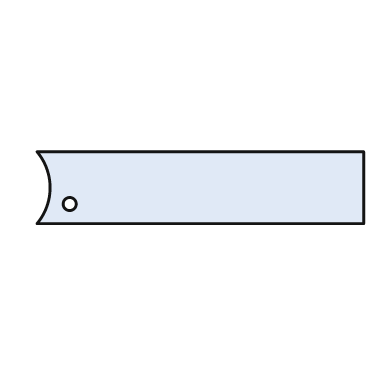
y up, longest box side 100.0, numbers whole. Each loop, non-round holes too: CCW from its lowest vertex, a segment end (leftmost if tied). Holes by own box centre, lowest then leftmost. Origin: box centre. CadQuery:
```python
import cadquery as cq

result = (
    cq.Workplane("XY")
    .moveTo(-50.0, -11.0)
    .lineTo(50.0, -11.0)
    .lineTo(50.0, 11.0)
    .lineTo(-50.0, 11.0)
    .threePointArc((-46.0, 0.0), (-50.0, -11.0))
    .close()
    .moveTo(-40.0, -5.0)
    .circle(2.0)
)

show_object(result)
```